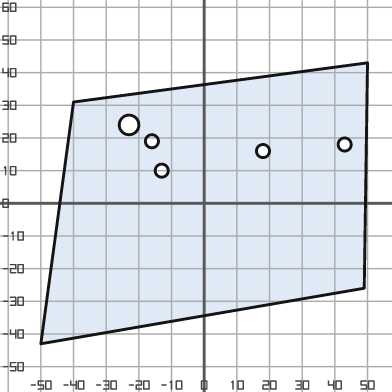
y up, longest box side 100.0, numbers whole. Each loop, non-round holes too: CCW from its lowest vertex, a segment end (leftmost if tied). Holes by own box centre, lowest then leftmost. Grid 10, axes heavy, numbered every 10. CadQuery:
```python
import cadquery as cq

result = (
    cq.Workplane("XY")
    .moveTo(-50.0, -43.0)
    .lineTo(49.0, -26.0)
    .lineTo(50.0, 43.0)
    .lineTo(-40.0, 31.0)
    .close()
    .moveTo(-13.0, 10.0)
    .circle(2.0)
    .moveTo(18.0, 16.0)
    .circle(2.0)
    .moveTo(43.0, 18.0)
    .circle(2.0)
    .moveTo(-16.0, 19.0)
    .circle(2.0)
    .moveTo(-23.0, 24.0)
    .circle(3.0)
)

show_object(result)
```